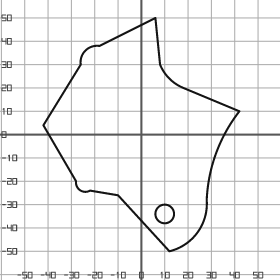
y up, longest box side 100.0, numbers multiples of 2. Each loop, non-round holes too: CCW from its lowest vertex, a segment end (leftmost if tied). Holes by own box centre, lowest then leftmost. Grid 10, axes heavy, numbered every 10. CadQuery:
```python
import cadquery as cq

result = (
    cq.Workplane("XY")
    .moveTo(12.0, -50.0)
    .threePointArc((24.0, -42.0), (28.0, -28.0))
    .threePointArc((32.0, -8.0), (42.0, 10.0))
    .lineTo(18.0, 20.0)
    .threePointArc((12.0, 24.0), (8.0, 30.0))
    .lineTo(6.0, 50.0)
    .lineTo(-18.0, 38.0)
    .threePointArc((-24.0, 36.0), (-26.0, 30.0))
    .lineTo(-42.0, 4.0)
    .lineTo(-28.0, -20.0)
    .threePointArc((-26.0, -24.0), (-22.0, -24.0))
    .lineTo(-10.0, -26.0)
    .close()
    .moveTo(10.0, -34.0)
    .circle(4.0)
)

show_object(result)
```